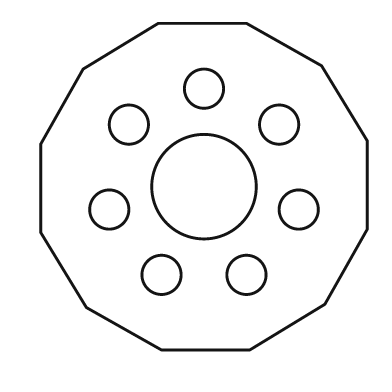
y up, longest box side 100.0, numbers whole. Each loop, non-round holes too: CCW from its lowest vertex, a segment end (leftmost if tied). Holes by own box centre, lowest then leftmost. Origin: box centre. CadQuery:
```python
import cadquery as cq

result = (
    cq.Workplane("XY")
    .moveTo(-13.0, -50.0)
    .lineTo(14.0, -50.0)
    .lineTo(37.0, -36.0)
    .lineTo(50.0, -13.0)
    .lineTo(50.0, 14.0)
    .lineTo(36.0, 37.0)
    .lineTo(13.0, 50.0)
    .lineTo(-14.0, 50.0)
    .lineTo(-37.0, 36.0)
    .lineTo(-50.0, 13.0)
    .lineTo(-50.0, -14.0)
    .lineTo(-36.0, -37.0)
    .close()
    .moveTo(-13.0, -27.0)
    .circle(6.0)
    .moveTo(13.0, -27.0)
    .circle(6.0)
    .moveTo(-29.0, -7.0)
    .circle(6.0)
    .moveTo(29.0, -7.0)
    .circle(6.0)
    .moveTo(0.0, 0.0)
    .circle(16.0)
    .moveTo(-23.0, 19.0)
    .circle(6.0)
    .moveTo(23.0, 19.0)
    .circle(6.0)
    .moveTo(0.0, 30.0)
    .circle(6.0)
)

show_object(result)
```